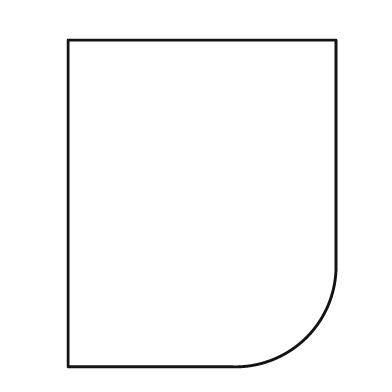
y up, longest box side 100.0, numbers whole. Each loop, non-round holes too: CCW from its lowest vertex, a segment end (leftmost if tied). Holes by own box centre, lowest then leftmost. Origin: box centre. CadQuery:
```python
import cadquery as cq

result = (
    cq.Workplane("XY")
    .moveTo(-41.0, -50.0)
    .lineTo(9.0, -50.0)
    .threePointArc((32.0, -41.0), (41.0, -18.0))
    .lineTo(41.0, 50.0)
    .lineTo(-41.0, 50.0)
    .close()
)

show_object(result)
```